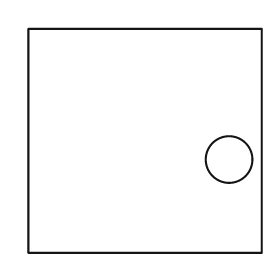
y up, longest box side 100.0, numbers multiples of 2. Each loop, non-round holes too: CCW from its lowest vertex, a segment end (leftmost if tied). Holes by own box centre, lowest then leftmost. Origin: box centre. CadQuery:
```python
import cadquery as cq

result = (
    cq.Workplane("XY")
    .moveTo(-50.0, -48.0)
    .lineTo(50.0, -48.0)
    .lineTo(50.0, 48.0)
    .lineTo(-50.0, 48.0)
    .close()
    .moveTo(36.0, -8.0)
    .circle(10.0)
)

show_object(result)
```